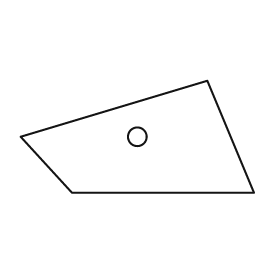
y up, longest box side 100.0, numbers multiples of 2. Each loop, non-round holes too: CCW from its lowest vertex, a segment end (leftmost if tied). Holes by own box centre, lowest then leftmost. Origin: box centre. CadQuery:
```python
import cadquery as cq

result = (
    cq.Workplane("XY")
    .moveTo(-28.0, -24.0)
    .lineTo(50.0, -24.0)
    .lineTo(30.0, 24.0)
    .lineTo(-50.0, 0.0)
    .close()
    .moveTo(0.0, 0.0)
    .circle(4.0)
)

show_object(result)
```